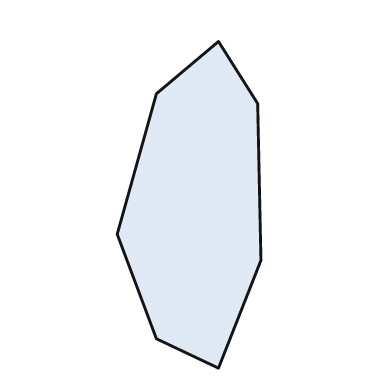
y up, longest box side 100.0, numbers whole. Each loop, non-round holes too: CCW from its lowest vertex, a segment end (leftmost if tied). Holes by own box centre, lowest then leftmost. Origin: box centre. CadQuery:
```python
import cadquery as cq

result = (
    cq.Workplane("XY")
    .moveTo(9.0, -50.0)
    .lineTo(22.0, -17.0)
    .lineTo(21.0, 31.0)
    .lineTo(9.0, 50.0)
    .lineTo(-10.0, 34.0)
    .lineTo(-22.0, -9.0)
    .lineTo(-10.0, -41.0)
    .close()
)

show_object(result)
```